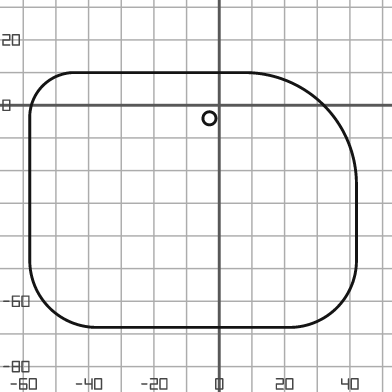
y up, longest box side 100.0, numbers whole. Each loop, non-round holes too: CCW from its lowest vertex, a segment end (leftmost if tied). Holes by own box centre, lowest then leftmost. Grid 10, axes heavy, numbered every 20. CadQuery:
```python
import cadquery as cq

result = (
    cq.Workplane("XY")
    .moveTo(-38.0, -68.0)
    .lineTo(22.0, -68.0)
    .threePointArc((36.0, -62.0), (42.0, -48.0))
    .lineTo(42.0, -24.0)
    .threePointArc((32.0, 0.0), (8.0, 10.0))
    .lineTo(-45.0, 10.0)
    .threePointArc((-54.0, 6.0), (-58.0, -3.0))
    .lineTo(-58.0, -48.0)
    .threePointArc((-52.0, -62.0), (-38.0, -68.0))
    .close()
    .moveTo(-3.0, -4.0)
    .circle(2.0)
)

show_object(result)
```